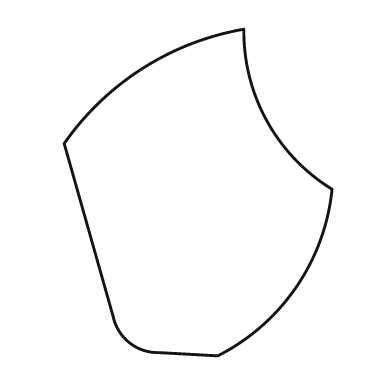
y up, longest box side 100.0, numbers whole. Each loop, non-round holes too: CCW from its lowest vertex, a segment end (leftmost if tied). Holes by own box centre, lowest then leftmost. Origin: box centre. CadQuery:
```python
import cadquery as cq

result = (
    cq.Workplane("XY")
    .moveTo(6.0, -50.0)
    .threePointArc((30.0, -29.0), (41.0, 1.0))
    .threePointArc((21.0, 22.0), (14.0, 50.0))
    .threePointArc((-17.0, 38.0), (-41.0, 15.0))
    .lineTo(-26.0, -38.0)
    .threePointArc((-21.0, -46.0), (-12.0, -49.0))
    .close()
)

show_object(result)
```